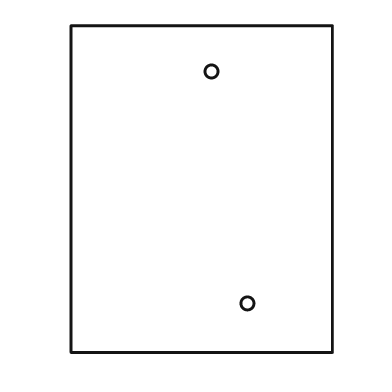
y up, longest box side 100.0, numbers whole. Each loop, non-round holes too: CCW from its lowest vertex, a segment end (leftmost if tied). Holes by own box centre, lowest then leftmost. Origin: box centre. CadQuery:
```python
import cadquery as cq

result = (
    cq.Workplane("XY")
    .moveTo(-40.0, -50.0)
    .lineTo(40.0, -50.0)
    .lineTo(40.0, 50.0)
    .lineTo(-40.0, 50.0)
    .close()
    .moveTo(14.0, -35.0)
    .circle(2.0)
    .moveTo(3.0, 36.0)
    .circle(2.0)
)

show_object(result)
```